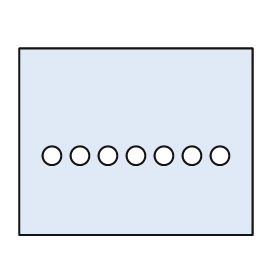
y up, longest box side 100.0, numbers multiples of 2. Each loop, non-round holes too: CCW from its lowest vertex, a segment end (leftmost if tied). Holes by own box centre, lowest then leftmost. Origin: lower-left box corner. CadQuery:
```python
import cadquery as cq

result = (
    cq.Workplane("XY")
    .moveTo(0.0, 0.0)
    .lineTo(100.0, 0.0)
    .lineTo(100.0, 80.0)
    .lineTo(0.0, 80.0)
    .close()
    .moveTo(14.0, 34.0)
    .circle(4.0)
    .moveTo(26.0, 34.0)
    .circle(4.0)
    .moveTo(38.0, 34.0)
    .circle(4.0)
    .moveTo(50.0, 34.0)
    .circle(4.0)
    .moveTo(62.0, 34.0)
    .circle(4.0)
    .moveTo(74.0, 34.0)
    .circle(4.0)
    .moveTo(86.0, 34.0)
    .circle(4.0)
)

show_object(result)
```